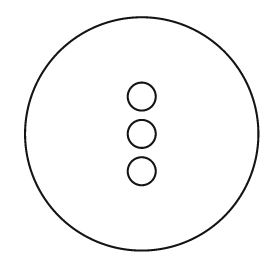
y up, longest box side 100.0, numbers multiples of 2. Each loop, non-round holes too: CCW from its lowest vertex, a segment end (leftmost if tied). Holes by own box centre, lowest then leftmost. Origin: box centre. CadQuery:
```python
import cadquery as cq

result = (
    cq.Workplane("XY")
    .moveTo(0.0, 0.0)
    .circle(50.0)
    .moveTo(0.0, -16.0)
    .circle(6.0)
    .moveTo(0.0, 0.0)
    .circle(6.0)
    .moveTo(0.0, 16.0)
    .circle(6.0)
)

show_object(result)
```